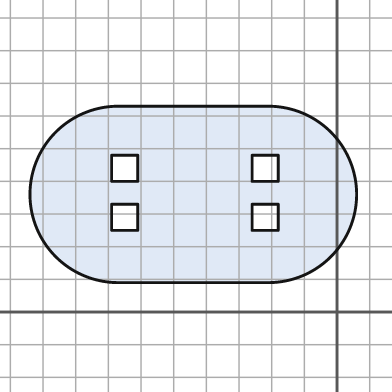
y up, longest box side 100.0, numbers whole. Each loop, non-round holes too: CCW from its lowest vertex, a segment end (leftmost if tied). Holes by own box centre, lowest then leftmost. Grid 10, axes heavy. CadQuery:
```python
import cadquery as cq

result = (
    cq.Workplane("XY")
    .moveTo(-67.0, 9.0)
    .lineTo(-21.0, 9.0)
    .threePointArc((6.0, 36.0), (-21.0, 63.0))
    .lineTo(-67.0, 63.0)
    .threePointArc((-94.0, 36.0), (-67.0, 9.0))
    .close()
    .moveTo(-69.0, 25.0)
    .lineTo(-61.0, 25.0)
    .lineTo(-61.0, 33.0)
    .lineTo(-69.0, 33.0)
    .close()
    .moveTo(-26.0, 25.0)
    .lineTo(-18.0, 25.0)
    .lineTo(-18.0, 33.0)
    .lineTo(-26.0, 33.0)
    .close()
    .moveTo(-69.0, 40.0)
    .lineTo(-61.0, 40.0)
    .lineTo(-61.0, 48.0)
    .lineTo(-69.0, 48.0)
    .close()
    .moveTo(-26.0, 40.0)
    .lineTo(-18.0, 40.0)
    .lineTo(-18.0, 48.0)
    .lineTo(-26.0, 48.0)
    .close()
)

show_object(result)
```